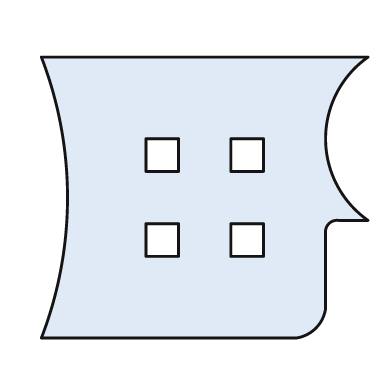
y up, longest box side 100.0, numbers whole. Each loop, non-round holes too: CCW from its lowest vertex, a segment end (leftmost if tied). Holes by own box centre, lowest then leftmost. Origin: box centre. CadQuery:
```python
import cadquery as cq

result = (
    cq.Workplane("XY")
    .moveTo(-50.0, -43.0)
    .lineTo(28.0, -43.0)
    .threePointArc((34.0, -40.0), (37.0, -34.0))
    .lineTo(37.0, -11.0)
    .threePointArc((38.0, -8.0), (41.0, -7.0))
    .lineTo(50.0, -7.0)
    .threePointArc((37.0, 18.0), (50.0, 43.0))
    .lineTo(-50.0, 43.0)
    .threePointArc((-42.0, 0.0), (-50.0, -43.0))
    .close()
    .moveTo(-18.0, -18.0)
    .lineTo(-8.0, -18.0)
    .lineTo(-8.0, -8.0)
    .lineTo(-18.0, -8.0)
    .close()
    .moveTo(8.0, -18.0)
    .lineTo(18.0, -18.0)
    .lineTo(18.0, -8.0)
    .lineTo(8.0, -8.0)
    .close()
    .moveTo(-18.0, 8.0)
    .lineTo(-8.0, 8.0)
    .lineTo(-8.0, 18.0)
    .lineTo(-18.0, 18.0)
    .close()
    .moveTo(8.0, 8.0)
    .lineTo(18.0, 8.0)
    .lineTo(18.0, 18.0)
    .lineTo(8.0, 18.0)
    .close()
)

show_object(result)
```